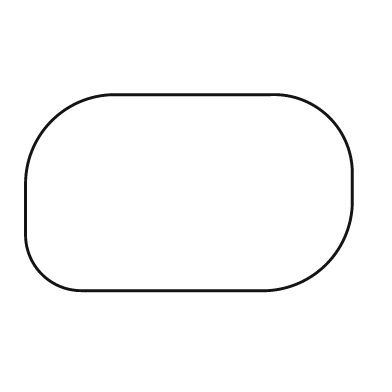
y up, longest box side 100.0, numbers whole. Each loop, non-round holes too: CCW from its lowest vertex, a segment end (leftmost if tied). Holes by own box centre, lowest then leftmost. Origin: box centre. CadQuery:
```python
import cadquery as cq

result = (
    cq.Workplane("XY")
    .moveTo(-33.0, -30.0)
    .lineTo(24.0, -30.0)
    .threePointArc((42.0, -22.0), (50.0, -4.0))
    .lineTo(50.0, 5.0)
    .threePointArc((43.0, 23.0), (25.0, 30.0))
    .lineTo(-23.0, 30.0)
    .threePointArc((-42.0, 22.0), (-50.0, 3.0))
    .lineTo(-50.0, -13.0)
    .threePointArc((-45.0, -25.0), (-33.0, -30.0))
    .close()
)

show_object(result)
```